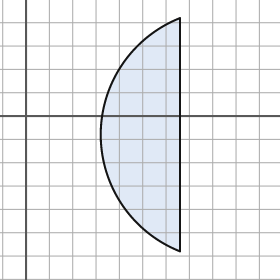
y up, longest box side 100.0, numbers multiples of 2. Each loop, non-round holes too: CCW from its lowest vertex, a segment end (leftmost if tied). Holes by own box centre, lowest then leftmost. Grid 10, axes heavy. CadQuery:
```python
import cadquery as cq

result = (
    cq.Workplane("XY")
    .moveTo(66.0, -58.0)
    .lineTo(66.0, 42.0)
    .threePointArc((32.0, -8.0), (66.0, -58.0))
    .close()
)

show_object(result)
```